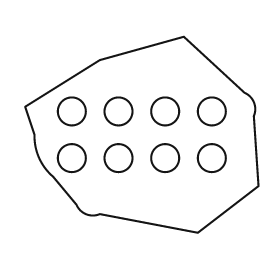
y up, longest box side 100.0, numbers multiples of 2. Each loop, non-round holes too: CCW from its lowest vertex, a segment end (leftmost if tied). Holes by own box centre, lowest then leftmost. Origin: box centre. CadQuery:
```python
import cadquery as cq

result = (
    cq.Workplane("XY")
    .moveTo(24.0, -42.0)
    .lineTo(50.0, -22.0)
    .lineTo(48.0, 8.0)
    .threePointArc((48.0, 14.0), (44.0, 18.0))
    .lineTo(18.0, 42.0)
    .lineTo(-18.0, 32.0)
    .lineTo(-50.0, 12.0)
    .lineTo(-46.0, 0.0)
    .threePointArc((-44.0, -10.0), (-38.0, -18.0))
    .lineTo(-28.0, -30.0)
    .threePointArc((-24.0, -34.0), (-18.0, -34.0))
    .close()
    .moveTo(-30.0, -10.0)
    .circle(6.0)
    .moveTo(-10.0, -10.0)
    .circle(6.0)
    .moveTo(10.0, -10.0)
    .circle(6.0)
    .moveTo(30.0, -10.0)
    .circle(6.0)
    .moveTo(-30.0, 10.0)
    .circle(6.0)
    .moveTo(-10.0, 10.0)
    .circle(6.0)
    .moveTo(10.0, 10.0)
    .circle(6.0)
    .moveTo(30.0, 10.0)
    .circle(6.0)
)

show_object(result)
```